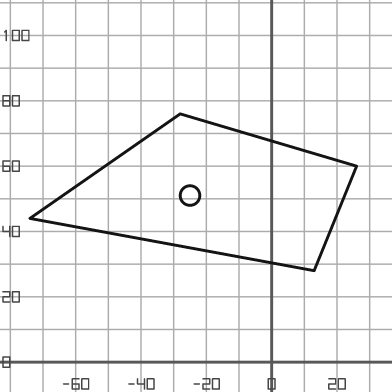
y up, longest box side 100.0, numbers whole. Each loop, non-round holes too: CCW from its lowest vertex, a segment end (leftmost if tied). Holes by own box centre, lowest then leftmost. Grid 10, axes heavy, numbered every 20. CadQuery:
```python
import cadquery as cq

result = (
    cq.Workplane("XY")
    .moveTo(13.0, 28.0)
    .lineTo(26.0, 60.0)
    .lineTo(-28.0, 76.0)
    .lineTo(-74.0, 44.0)
    .close()
    .moveTo(-25.0, 51.0)
    .circle(3.0)
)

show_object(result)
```